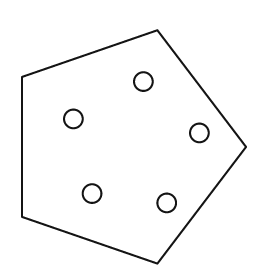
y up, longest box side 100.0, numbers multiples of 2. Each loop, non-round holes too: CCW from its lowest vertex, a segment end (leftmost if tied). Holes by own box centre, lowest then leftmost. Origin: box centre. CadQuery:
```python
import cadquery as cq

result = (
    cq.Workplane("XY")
    .moveTo(10.0, -50.0)
    .lineTo(48.0, 0.0)
    .lineTo(10.0, 50.0)
    .lineTo(-48.0, 30.0)
    .lineTo(-48.0, -30.0)
    .close()
    .moveTo(14.0, -24.0)
    .circle(4.0)
    .moveTo(-18.0, -20.0)
    .circle(4.0)
    .moveTo(28.0, 6.0)
    .circle(4.0)
    .moveTo(-26.0, 12.0)
    .circle(4.0)
    .moveTo(4.0, 28.0)
    .circle(4.0)
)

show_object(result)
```